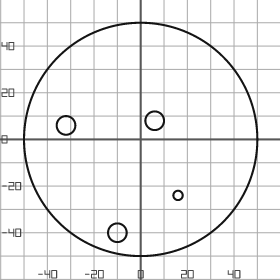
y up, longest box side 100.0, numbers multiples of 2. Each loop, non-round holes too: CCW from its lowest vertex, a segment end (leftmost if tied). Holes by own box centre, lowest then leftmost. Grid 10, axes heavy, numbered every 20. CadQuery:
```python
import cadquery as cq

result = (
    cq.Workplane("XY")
    .moveTo(0.0, 0.0)
    .circle(50.0)
    .moveTo(-10.0, -40.0)
    .circle(4.0)
    .moveTo(16.0, -24.0)
    .circle(2.0)
    .moveTo(-32.0, 6.0)
    .circle(4.0)
    .moveTo(6.0, 8.0)
    .circle(4.0)
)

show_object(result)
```